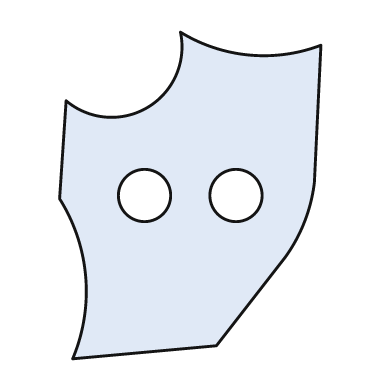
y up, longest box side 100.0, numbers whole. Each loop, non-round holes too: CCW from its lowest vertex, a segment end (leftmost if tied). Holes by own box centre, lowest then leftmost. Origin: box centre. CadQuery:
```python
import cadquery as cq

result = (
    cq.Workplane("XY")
    .moveTo(-36.0, -50.0)
    .lineTo(8.0, -46.0)
    .lineTo(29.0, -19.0)
    .threePointArc((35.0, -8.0), (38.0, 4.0))
    .lineTo(40.0, 46.0)
    .threePointArc((18.0, 43.0), (-3.0, 50.0))
    .threePointArc((-13.0, 27.0), (-38.0, 29.0))
    .lineTo(-40.0, -1.0)
    .threePointArc((-32.0, -25.0), (-36.0, -50.0))
    .close()
    .moveTo(-14.0, 0.0)
    .circle(8.0)
    .moveTo(14.0, 0.0)
    .circle(8.0)
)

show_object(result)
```